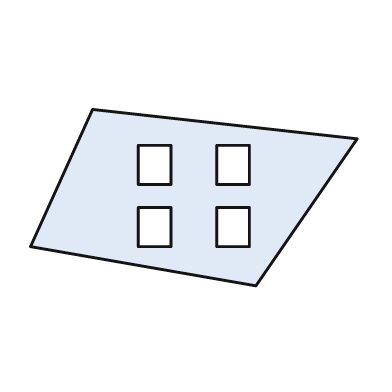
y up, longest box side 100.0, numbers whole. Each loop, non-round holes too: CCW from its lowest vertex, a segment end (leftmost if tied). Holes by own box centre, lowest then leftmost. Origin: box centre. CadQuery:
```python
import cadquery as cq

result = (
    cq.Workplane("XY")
    .moveTo(19.0, -27.0)
    .lineTo(50.0, 18.0)
    .lineTo(-31.0, 27.0)
    .lineTo(-50.0, -15.0)
    .close()
    .moveTo(-17.0, -15.0)
    .lineTo(-7.0, -15.0)
    .lineTo(-7.0, -3.0)
    .lineTo(-17.0, -3.0)
    .close()
    .moveTo(7.0, -15.0)
    .lineTo(17.0, -15.0)
    .lineTo(17.0, -3.0)
    .lineTo(7.0, -3.0)
    .close()
    .moveTo(-17.0, 4.0)
    .lineTo(-7.0, 4.0)
    .lineTo(-7.0, 16.0)
    .lineTo(-17.0, 16.0)
    .close()
    .moveTo(7.0, 4.0)
    .lineTo(17.0, 4.0)
    .lineTo(17.0, 16.0)
    .lineTo(7.0, 16.0)
    .close()
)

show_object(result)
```